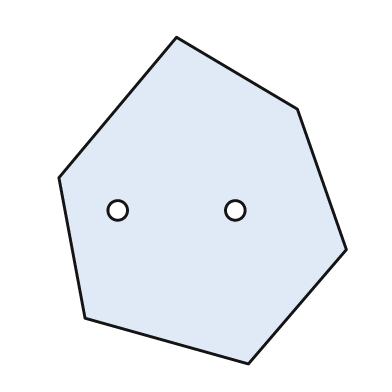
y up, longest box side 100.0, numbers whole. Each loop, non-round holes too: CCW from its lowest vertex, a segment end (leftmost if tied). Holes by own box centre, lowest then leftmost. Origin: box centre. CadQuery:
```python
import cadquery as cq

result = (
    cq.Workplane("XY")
    .moveTo(14.0, -50.0)
    .lineTo(44.0, -15.0)
    .lineTo(29.0, 28.0)
    .lineTo(-8.0, 50.0)
    .lineTo(-44.0, 7.0)
    .lineTo(-36.0, -36.0)
    .close()
    .moveTo(-26.0, -3.0)
    .circle(3.0)
    .moveTo(10.0, -3.0)
    .circle(3.0)
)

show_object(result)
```